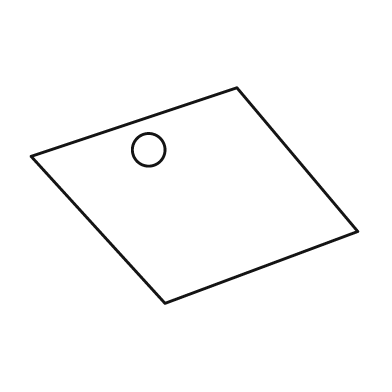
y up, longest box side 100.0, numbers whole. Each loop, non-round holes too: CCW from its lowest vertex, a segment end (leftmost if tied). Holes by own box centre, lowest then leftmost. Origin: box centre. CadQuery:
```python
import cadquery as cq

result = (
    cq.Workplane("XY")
    .moveTo(-9.0, -33.0)
    .lineTo(50.0, -11.0)
    .lineTo(13.0, 33.0)
    .lineTo(-50.0, 12.0)
    .close()
    .moveTo(-14.0, 14.0)
    .circle(5.0)
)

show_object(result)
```